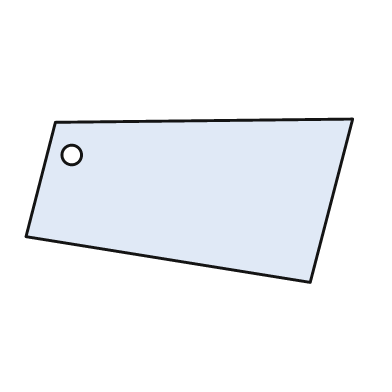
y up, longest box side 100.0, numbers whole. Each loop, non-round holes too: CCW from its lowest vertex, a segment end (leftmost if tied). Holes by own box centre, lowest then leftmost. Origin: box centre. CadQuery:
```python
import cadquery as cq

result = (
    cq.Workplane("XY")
    .moveTo(37.0, -25.0)
    .lineTo(50.0, 25.0)
    .lineTo(-41.0, 24.0)
    .lineTo(-50.0, -11.0)
    .close()
    .moveTo(-36.0, 14.0)
    .circle(3.0)
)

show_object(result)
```